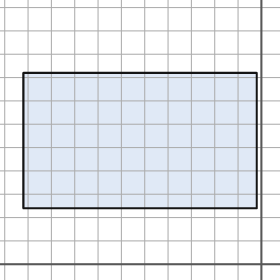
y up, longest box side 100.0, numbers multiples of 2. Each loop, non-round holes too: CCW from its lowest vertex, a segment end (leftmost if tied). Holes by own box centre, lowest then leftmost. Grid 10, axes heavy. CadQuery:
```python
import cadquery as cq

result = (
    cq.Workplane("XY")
    .moveTo(-102.0, 24.0)
    .lineTo(-2.0, 24.0)
    .lineTo(-2.0, 82.0)
    .lineTo(-102.0, 82.0)
    .close()
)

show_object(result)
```